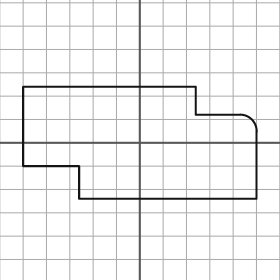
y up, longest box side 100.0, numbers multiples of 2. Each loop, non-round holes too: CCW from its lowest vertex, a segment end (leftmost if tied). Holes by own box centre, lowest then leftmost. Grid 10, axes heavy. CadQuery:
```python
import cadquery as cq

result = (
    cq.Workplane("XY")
    .moveTo(-26.0, -24.0)
    .lineTo(50.0, -24.0)
    .lineTo(50.0, 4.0)
    .threePointArc((48.0, 10.0), (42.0, 12.0))
    .lineTo(24.0, 12.0)
    .lineTo(24.0, 24.0)
    .lineTo(-50.0, 24.0)
    .lineTo(-50.0, -10.0)
    .lineTo(-26.0, -10.0)
    .close()
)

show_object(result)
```